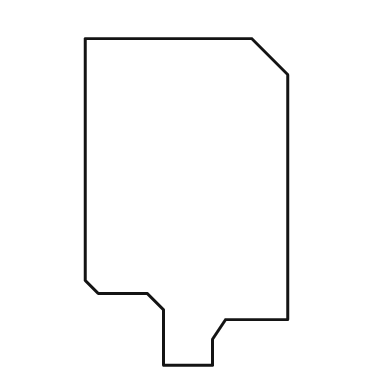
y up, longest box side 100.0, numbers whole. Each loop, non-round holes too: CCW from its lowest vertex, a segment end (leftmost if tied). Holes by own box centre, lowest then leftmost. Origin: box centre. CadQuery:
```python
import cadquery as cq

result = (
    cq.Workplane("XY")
    .moveTo(-7.0, -50.0)
    .lineTo(8.0, -50.0)
    .lineTo(8.0, -42.0)
    .lineTo(12.0, -36.0)
    .lineTo(31.0, -36.0)
    .lineTo(31.0, 39.0)
    .lineTo(20.0, 50.0)
    .lineTo(-31.0, 50.0)
    .lineTo(-31.0, -24.0)
    .lineTo(-27.0, -28.0)
    .lineTo(-12.0, -28.0)
    .lineTo(-7.0, -33.0)
    .close()
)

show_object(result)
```